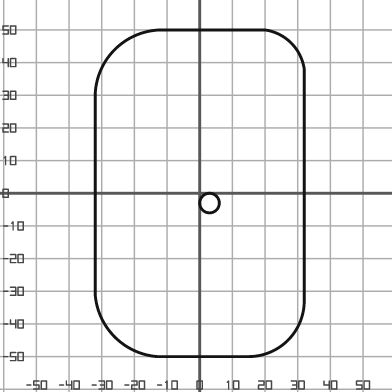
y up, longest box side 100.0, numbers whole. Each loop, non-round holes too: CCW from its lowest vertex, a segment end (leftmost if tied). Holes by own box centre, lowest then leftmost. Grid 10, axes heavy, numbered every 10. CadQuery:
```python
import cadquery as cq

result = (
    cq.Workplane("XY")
    .moveTo(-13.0, -50.0)
    .lineTo(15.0, -50.0)
    .threePointArc((27.0, -45.0), (32.0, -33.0))
    .lineTo(32.0, 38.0)
    .threePointArc((28.0, 46.0), (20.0, 50.0))
    .lineTo(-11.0, 50.0)
    .threePointArc((-26.0, 44.0), (-32.0, 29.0))
    .lineTo(-32.0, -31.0)
    .threePointArc((-26.0, -44.0), (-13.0, -50.0))
    .close()
    .moveTo(3.0, -3.0)
    .circle(3.0)
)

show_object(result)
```